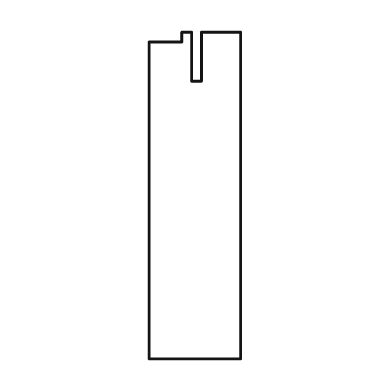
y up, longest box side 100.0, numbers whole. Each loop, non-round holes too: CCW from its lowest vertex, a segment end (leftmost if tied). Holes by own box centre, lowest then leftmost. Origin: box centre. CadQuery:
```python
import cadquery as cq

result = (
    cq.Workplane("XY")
    .moveTo(-14.0, -50.0)
    .lineTo(14.0, -50.0)
    .lineTo(14.0, 50.0)
    .lineTo(2.0, 50.0)
    .lineTo(2.0, 35.0)
    .lineTo(-1.0, 35.0)
    .lineTo(-1.0, 50.0)
    .lineTo(-4.0, 50.0)
    .lineTo(-4.0, 47.0)
    .lineTo(-14.0, 47.0)
    .close()
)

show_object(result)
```